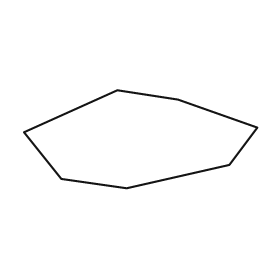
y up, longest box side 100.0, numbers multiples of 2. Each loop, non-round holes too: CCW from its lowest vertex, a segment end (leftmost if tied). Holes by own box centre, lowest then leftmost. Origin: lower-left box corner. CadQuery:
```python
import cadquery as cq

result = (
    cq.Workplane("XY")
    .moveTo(44.0, 0.0)
    .lineTo(88.0, 10.0)
    .lineTo(100.0, 26.0)
    .lineTo(66.0, 38.0)
    .lineTo(40.0, 42.0)
    .lineTo(0.0, 24.0)
    .lineTo(16.0, 4.0)
    .close()
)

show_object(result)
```